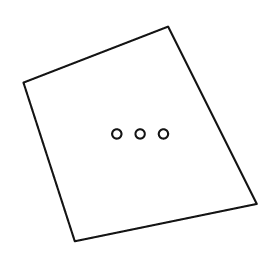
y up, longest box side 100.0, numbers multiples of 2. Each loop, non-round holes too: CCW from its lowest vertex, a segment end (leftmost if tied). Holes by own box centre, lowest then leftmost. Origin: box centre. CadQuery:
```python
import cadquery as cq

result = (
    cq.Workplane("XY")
    .moveTo(-28.0, -46.0)
    .lineTo(50.0, -30.0)
    .lineTo(12.0, 46.0)
    .lineTo(-50.0, 22.0)
    .close()
    .moveTo(-10.0, 0.0)
    .circle(2.0)
    .moveTo(0.0, 0.0)
    .circle(2.0)
    .moveTo(10.0, 0.0)
    .circle(2.0)
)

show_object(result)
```